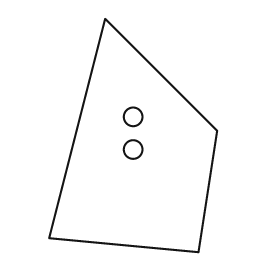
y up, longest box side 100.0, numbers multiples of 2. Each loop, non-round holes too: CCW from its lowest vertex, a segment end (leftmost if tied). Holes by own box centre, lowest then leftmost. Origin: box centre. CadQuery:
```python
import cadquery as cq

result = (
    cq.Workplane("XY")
    .moveTo(28.0, -50.0)
    .lineTo(36.0, 2.0)
    .lineTo(-12.0, 50.0)
    .lineTo(-36.0, -44.0)
    .close()
    .moveTo(0.0, -6.0)
    .circle(4.0)
    .moveTo(0.0, 8.0)
    .circle(4.0)
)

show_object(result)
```